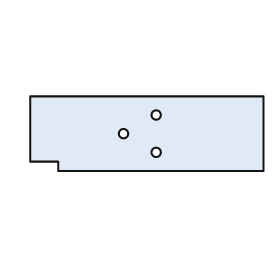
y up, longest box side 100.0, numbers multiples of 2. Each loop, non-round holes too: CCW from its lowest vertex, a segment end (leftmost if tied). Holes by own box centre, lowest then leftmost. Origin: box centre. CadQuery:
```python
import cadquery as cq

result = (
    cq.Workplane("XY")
    .moveTo(-38.0, -16.0)
    .lineTo(50.0, -16.0)
    .lineTo(50.0, 16.0)
    .lineTo(-50.0, 16.0)
    .lineTo(-50.0, -12.0)
    .lineTo(-38.0, -12.0)
    .close()
    .moveTo(4.0, -8.0)
    .circle(2.0)
    .moveTo(-10.0, 0.0)
    .circle(2.0)
    .moveTo(4.0, 8.0)
    .circle(2.0)
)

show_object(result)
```